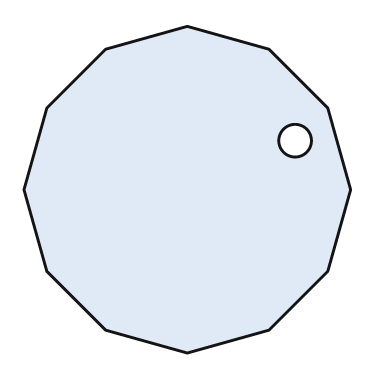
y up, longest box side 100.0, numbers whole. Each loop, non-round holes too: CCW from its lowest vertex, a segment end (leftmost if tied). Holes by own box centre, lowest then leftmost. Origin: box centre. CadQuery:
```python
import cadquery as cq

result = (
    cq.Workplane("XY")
    .moveTo(0.0, -50.0)
    .lineTo(25.0, -43.0)
    .lineTo(43.0, -25.0)
    .lineTo(50.0, 0.0)
    .lineTo(43.0, 25.0)
    .lineTo(25.0, 43.0)
    .lineTo(0.0, 50.0)
    .lineTo(-25.0, 43.0)
    .lineTo(-43.0, 25.0)
    .lineTo(-50.0, 0.0)
    .lineTo(-43.0, -25.0)
    .lineTo(-25.0, -43.0)
    .close()
    .moveTo(33.0, 15.0)
    .circle(5.0)
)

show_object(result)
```